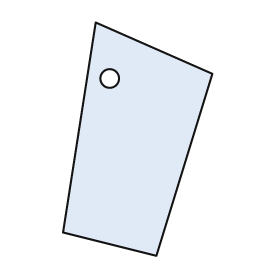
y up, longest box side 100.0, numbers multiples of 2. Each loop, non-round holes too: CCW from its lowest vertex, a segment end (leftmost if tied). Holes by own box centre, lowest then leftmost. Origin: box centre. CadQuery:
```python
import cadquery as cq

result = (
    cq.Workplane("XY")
    .moveTo(8.0, -50.0)
    .lineTo(32.0, 28.0)
    .lineTo(-18.0, 50.0)
    .lineTo(-32.0, -40.0)
    .close()
    .moveTo(-12.0, 26.0)
    .circle(4.0)
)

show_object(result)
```